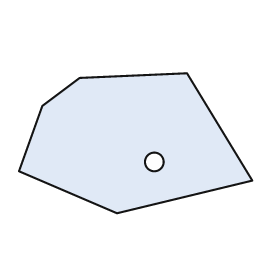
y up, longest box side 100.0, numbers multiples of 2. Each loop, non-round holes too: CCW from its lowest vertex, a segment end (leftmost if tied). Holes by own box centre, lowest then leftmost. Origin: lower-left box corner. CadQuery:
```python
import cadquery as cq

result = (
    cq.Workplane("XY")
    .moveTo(42.0, 0.0)
    .lineTo(100.0, 14.0)
    .lineTo(72.0, 60.0)
    .lineTo(26.0, 58.0)
    .lineTo(10.0, 46.0)
    .lineTo(0.0, 18.0)
    .close()
    .moveTo(58.0, 22.0)
    .circle(4.0)
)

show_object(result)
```